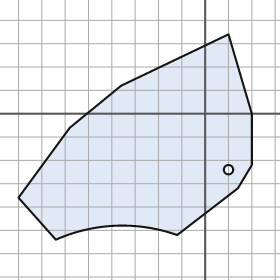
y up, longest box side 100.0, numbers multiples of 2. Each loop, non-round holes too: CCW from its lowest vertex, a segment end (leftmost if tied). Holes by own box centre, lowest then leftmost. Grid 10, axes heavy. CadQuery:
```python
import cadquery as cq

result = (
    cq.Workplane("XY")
    .moveTo(-64.0, -54.0)
    .threePointArc((-38.0, -48.0), (-12.0, -52.0))
    .lineTo(14.0, -32.0)
    .lineTo(20.0, -22.0)
    .lineTo(20.0, 0.0)
    .lineTo(10.0, 34.0)
    .lineTo(-36.0, 12.0)
    .lineTo(-58.0, -6.0)
    .lineTo(-80.0, -36.0)
    .close()
    .moveTo(10.0, -24.0)
    .circle(2.0)
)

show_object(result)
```